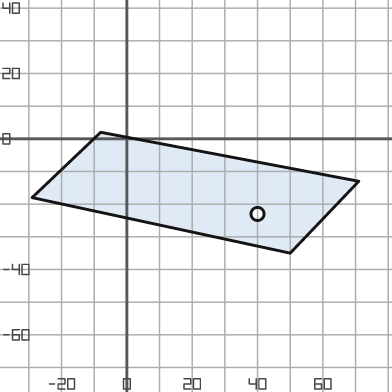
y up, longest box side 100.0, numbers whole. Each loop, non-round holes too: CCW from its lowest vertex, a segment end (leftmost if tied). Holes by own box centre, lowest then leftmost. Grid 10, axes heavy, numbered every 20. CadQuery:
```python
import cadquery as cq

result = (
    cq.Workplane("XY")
    .moveTo(50.0, -35.0)
    .lineTo(71.0, -13.0)
    .lineTo(-8.0, 2.0)
    .lineTo(-29.0, -18.0)
    .close()
    .moveTo(40.0, -23.0)
    .circle(2.0)
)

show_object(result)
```